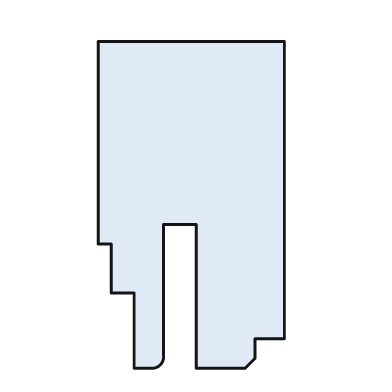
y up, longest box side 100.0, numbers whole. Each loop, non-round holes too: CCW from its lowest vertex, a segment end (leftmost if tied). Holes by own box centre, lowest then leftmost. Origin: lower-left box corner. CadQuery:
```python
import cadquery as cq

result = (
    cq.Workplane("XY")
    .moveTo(11.0, 0.0)
    .lineTo(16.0, 0.0)
    .threePointArc((19.0, 1.0), (20.0, 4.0))
    .lineTo(20.0, 44.0)
    .lineTo(30.0, 44.0)
    .lineTo(30.0, 0.0)
    .lineTo(45.0, 0.0)
    .lineTo(48.0, 3.0)
    .lineTo(48.0, 9.0)
    .lineTo(57.0, 9.0)
    .lineTo(57.0, 100.0)
    .lineTo(0.0, 100.0)
    .lineTo(0.0, 38.0)
    .lineTo(4.0, 38.0)
    .lineTo(4.0, 23.0)
    .lineTo(11.0, 23.0)
    .close()
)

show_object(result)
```